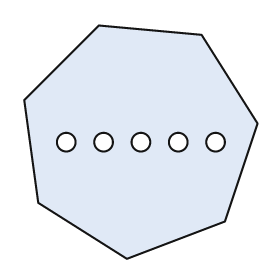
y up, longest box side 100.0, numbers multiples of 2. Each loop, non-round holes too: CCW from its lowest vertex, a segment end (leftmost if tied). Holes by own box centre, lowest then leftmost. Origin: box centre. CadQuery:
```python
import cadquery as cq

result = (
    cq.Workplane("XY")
    .moveTo(-6.0, -50.0)
    .lineTo(36.0, -34.0)
    .lineTo(50.0, 8.0)
    .lineTo(26.0, 46.0)
    .lineTo(-18.0, 50.0)
    .lineTo(-50.0, 18.0)
    .lineTo(-44.0, -26.0)
    .close()
    .moveTo(-32.0, 0.0)
    .circle(4.0)
    .moveTo(-16.0, 0.0)
    .circle(4.0)
    .moveTo(0.0, 0.0)
    .circle(4.0)
    .moveTo(16.0, 0.0)
    .circle(4.0)
    .moveTo(32.0, 0.0)
    .circle(4.0)
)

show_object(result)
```